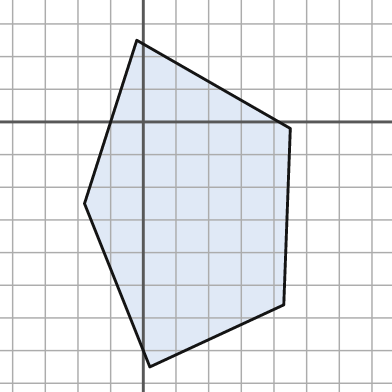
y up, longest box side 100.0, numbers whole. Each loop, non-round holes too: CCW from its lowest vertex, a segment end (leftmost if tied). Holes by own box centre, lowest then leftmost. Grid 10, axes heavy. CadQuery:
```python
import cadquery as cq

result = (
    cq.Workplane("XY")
    .moveTo(2.0, -75.0)
    .lineTo(43.0, -56.0)
    .lineTo(45.0, -2.0)
    .lineTo(-2.0, 25.0)
    .lineTo(-18.0, -25.0)
    .close()
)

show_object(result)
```